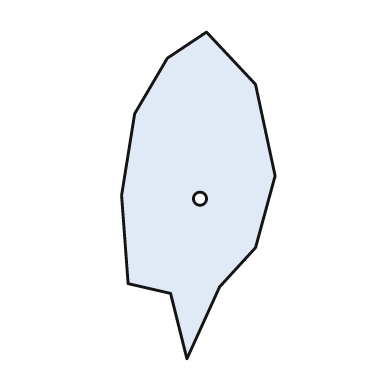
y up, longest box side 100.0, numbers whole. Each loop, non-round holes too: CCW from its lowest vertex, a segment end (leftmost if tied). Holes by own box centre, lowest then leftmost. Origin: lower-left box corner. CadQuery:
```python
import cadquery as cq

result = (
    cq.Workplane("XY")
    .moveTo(20.0, 0.0)
    .lineTo(30.0, 22.0)
    .lineTo(41.0, 34.0)
    .lineTo(47.0, 56.0)
    .lineTo(41.0, 84.0)
    .lineTo(26.0, 100.0)
    .lineTo(14.0, 92.0)
    .lineTo(4.0, 75.0)
    .lineTo(0.0, 50.0)
    .lineTo(2.0, 23.0)
    .lineTo(15.0, 20.0)
    .close()
    .moveTo(24.0, 49.0)
    .circle(2.0)
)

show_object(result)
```